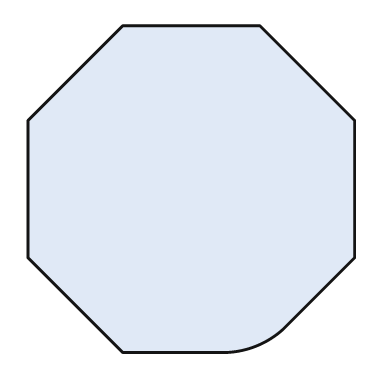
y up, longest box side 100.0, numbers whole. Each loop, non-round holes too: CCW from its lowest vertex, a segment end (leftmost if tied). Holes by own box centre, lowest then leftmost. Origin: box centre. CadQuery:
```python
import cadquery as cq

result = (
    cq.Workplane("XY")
    .moveTo(-21.0, -50.0)
    .lineTo(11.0, -50.0)
    .threePointArc((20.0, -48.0), (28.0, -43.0))
    .lineTo(50.0, -21.0)
    .lineTo(50.0, 21.0)
    .lineTo(21.0, 50.0)
    .lineTo(-21.0, 50.0)
    .lineTo(-50.0, 21.0)
    .lineTo(-50.0, -21.0)
    .close()
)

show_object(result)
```